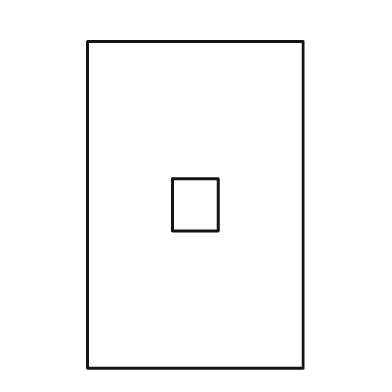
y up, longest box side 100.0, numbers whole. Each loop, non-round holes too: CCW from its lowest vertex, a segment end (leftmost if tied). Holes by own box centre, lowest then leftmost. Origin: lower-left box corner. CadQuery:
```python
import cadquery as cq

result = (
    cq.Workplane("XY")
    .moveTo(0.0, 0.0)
    .lineTo(66.0, 0.0)
    .lineTo(66.0, 100.0)
    .lineTo(0.0, 100.0)
    .close()
    .moveTo(26.0, 42.0)
    .lineTo(40.0, 42.0)
    .lineTo(40.0, 58.0)
    .lineTo(26.0, 58.0)
    .close()
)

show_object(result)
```